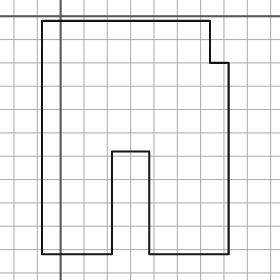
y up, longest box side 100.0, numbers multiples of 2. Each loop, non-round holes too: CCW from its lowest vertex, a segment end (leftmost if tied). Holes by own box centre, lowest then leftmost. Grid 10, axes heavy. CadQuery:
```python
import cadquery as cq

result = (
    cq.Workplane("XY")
    .moveTo(-8.0, -102.0)
    .lineTo(22.0, -102.0)
    .lineTo(22.0, -58.0)
    .lineTo(38.0, -58.0)
    .lineTo(38.0, -102.0)
    .lineTo(72.0, -102.0)
    .lineTo(72.0, -20.0)
    .lineTo(64.0, -20.0)
    .lineTo(64.0, -2.0)
    .lineTo(-8.0, -2.0)
    .close()
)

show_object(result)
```